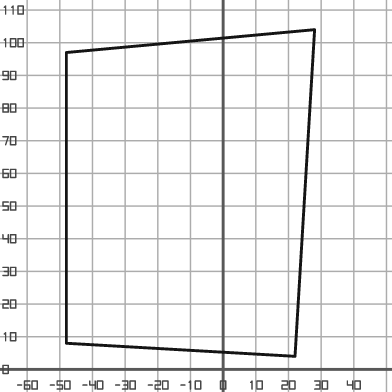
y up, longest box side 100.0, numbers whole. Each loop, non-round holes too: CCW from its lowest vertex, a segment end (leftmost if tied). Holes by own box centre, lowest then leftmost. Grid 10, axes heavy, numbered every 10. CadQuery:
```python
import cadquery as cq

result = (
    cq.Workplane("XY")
    .moveTo(22.0, 4.0)
    .lineTo(28.0, 104.0)
    .lineTo(-48.0, 97.0)
    .lineTo(-48.0, 8.0)
    .close()
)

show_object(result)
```